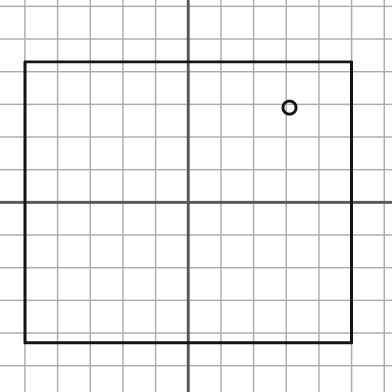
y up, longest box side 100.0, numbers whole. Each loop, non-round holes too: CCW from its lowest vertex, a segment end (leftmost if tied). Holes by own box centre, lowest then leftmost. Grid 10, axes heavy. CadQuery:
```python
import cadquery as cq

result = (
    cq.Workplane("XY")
    .moveTo(-50.0, -43.0)
    .lineTo(50.0, -43.0)
    .lineTo(50.0, 43.0)
    .lineTo(-50.0, 43.0)
    .close()
    .moveTo(31.0, 29.0)
    .circle(2.0)
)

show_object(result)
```